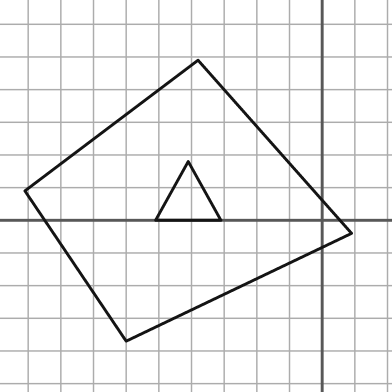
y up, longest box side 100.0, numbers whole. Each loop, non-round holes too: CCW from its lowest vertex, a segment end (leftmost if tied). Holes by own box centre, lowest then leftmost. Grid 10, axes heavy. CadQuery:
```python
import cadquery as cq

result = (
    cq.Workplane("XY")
    .moveTo(-60.0, -37.0)
    .lineTo(9.0, -4.0)
    .lineTo(-38.0, 49.0)
    .lineTo(-91.0, 9.0)
    .close()
    .moveTo(-51.0, 0.0)
    .lineTo(-31.0, 0.0)
    .lineTo(-41.0, 18.0)
    .close()
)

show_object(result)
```